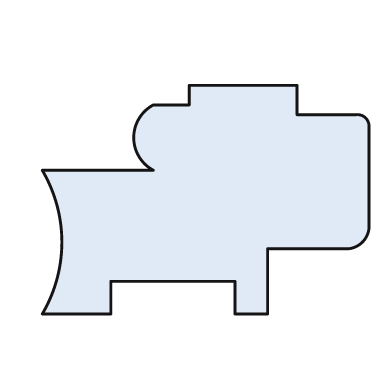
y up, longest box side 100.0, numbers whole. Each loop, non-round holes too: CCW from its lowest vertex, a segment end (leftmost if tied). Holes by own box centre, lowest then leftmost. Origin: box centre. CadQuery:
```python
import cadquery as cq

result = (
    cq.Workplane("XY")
    .moveTo(-50.0, -35.0)
    .lineTo(-29.0, -35.0)
    .lineTo(-29.0, -25.0)
    .lineTo(9.0, -25.0)
    .lineTo(9.0, -35.0)
    .lineTo(19.0, -35.0)
    .lineTo(19.0, -15.0)
    .lineTo(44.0, -15.0)
    .threePointArc((48.0, -13.0), (50.0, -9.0))
    .lineTo(50.0, 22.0)
    .threePointArc((49.0, 25.0), (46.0, 26.0))
    .lineTo(28.0, 26.0)
    .lineTo(28.0, 35.0)
    .lineTo(-5.0, 35.0)
    .lineTo(-5.0, 29.0)
    .lineTo(-16.0, 29.0)
    .threePointArc((-22.0, 19.0), (-16.0, 9.0))
    .lineTo(-50.0, 9.0)
    .threePointArc((-44.0, -13.0), (-50.0, -35.0))
    .close()
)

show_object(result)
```